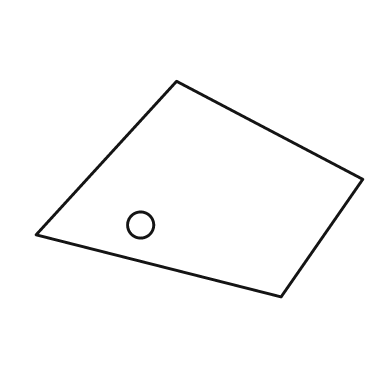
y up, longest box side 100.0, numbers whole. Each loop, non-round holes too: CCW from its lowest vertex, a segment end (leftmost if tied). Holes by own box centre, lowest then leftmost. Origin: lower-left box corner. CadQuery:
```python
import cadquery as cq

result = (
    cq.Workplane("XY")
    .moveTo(75.0, 0.0)
    .lineTo(100.0, 36.0)
    .lineTo(43.0, 66.0)
    .lineTo(0.0, 19.0)
    .close()
    .moveTo(32.0, 22.0)
    .circle(4.0)
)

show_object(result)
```